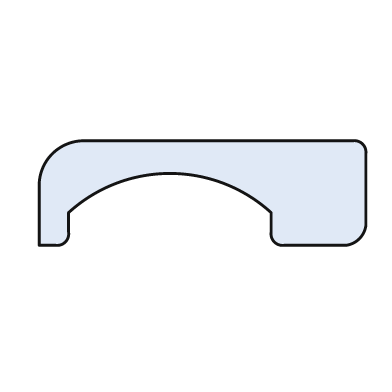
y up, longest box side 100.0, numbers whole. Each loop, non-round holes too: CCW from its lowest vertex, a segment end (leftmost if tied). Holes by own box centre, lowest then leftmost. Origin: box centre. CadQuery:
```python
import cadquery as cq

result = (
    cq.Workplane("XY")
    .moveTo(-50.0, -16.0)
    .lineTo(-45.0, -16.0)
    .threePointArc((-42.0, -15.0), (-41.0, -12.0))
    .lineTo(-41.0, -6.0)
    .threePointArc((-10.0, 6.0), (21.0, -6.0))
    .lineTo(21.0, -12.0)
    .threePointArc((22.0, -15.0), (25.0, -16.0))
    .lineTo(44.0, -16.0)
    .threePointArc((48.0, -14.0), (50.0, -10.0))
    .lineTo(50.0, 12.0)
    .threePointArc((49.0, 15.0), (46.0, 16.0))
    .lineTo(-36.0, 16.0)
    .threePointArc((-46.0, 12.0), (-50.0, 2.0))
    .close()
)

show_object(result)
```